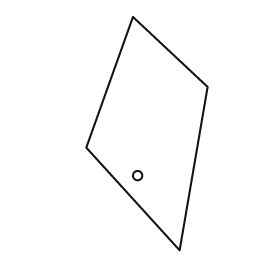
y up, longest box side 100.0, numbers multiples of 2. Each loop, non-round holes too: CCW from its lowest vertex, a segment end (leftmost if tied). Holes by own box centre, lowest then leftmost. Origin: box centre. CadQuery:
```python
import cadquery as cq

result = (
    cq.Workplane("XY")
    .moveTo(14.0, -50.0)
    .lineTo(26.0, 20.0)
    .lineTo(-6.0, 50.0)
    .lineTo(-26.0, -6.0)
    .close()
    .moveTo(-4.0, -18.0)
    .circle(2.0)
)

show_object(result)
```